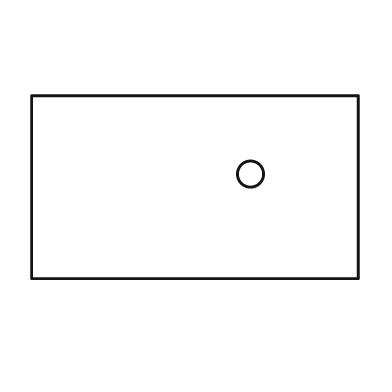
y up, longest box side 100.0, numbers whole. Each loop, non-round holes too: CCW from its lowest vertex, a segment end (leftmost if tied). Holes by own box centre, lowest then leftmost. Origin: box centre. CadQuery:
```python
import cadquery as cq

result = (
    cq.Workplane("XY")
    .moveTo(-50.0, -28.0)
    .lineTo(50.0, -28.0)
    .lineTo(50.0, 28.0)
    .lineTo(-50.0, 28.0)
    .close()
    .moveTo(17.0, 4.0)
    .circle(4.0)
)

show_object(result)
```